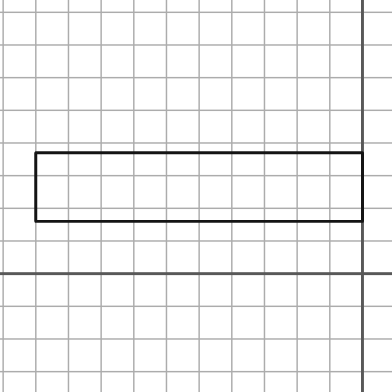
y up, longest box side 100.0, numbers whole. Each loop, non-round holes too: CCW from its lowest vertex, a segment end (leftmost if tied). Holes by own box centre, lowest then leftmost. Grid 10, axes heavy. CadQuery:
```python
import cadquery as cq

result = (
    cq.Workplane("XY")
    .moveTo(-100.0, 16.0)
    .lineTo(0.0, 16.0)
    .lineTo(0.0, 37.0)
    .lineTo(-100.0, 37.0)
    .close()
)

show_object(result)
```